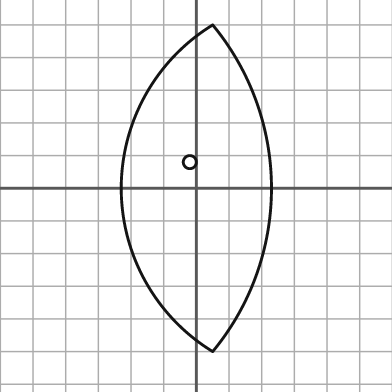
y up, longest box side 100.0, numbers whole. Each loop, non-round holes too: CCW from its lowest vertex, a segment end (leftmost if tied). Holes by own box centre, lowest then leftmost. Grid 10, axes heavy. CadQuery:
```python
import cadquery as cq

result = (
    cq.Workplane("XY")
    .moveTo(5.0, -50.0)
    .threePointArc((23.0, 0.0), (5.0, 50.0))
    .threePointArc((-23.0, 0.0), (5.0, -50.0))
    .close()
    .moveTo(-2.0, 8.0)
    .circle(2.0)
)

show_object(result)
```